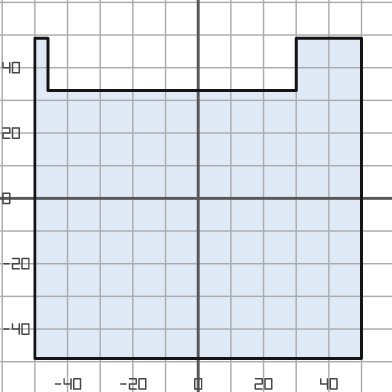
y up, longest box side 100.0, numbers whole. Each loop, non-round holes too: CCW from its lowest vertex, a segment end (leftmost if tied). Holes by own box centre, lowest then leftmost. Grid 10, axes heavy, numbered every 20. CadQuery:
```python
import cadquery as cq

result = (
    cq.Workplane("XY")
    .moveTo(-50.0, -49.0)
    .lineTo(50.0, -49.0)
    .lineTo(50.0, 49.0)
    .lineTo(30.0, 49.0)
    .lineTo(30.0, 33.0)
    .lineTo(-46.0, 33.0)
    .lineTo(-46.0, 49.0)
    .lineTo(-50.0, 49.0)
    .close()
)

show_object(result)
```